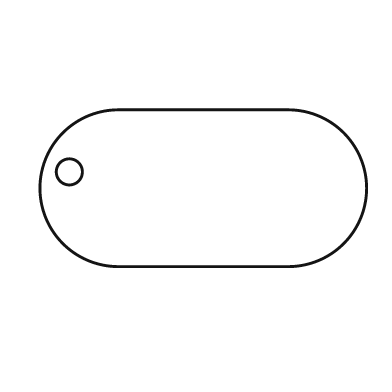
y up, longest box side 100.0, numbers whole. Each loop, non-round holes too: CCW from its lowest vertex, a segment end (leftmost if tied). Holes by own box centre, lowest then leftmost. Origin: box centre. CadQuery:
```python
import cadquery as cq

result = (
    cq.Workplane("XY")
    .moveTo(-26.0, -24.0)
    .lineTo(26.0, -24.0)
    .threePointArc((50.0, 0.0), (26.0, 24.0))
    .lineTo(-26.0, 24.0)
    .threePointArc((-50.0, 0.0), (-26.0, -24.0))
    .close()
    .moveTo(-41.0, 5.0)
    .circle(4.0)
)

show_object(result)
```